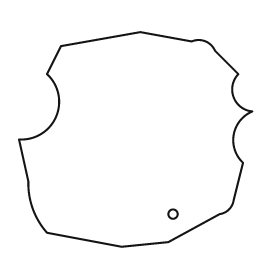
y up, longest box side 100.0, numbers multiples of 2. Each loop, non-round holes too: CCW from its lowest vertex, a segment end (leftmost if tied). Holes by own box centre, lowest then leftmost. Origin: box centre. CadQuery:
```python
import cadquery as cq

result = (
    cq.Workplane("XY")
    .moveTo(-6.0, -46.0)
    .lineTo(14.0, -44.0)
    .lineTo(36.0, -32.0)
    .threePointArc((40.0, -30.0), (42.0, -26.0))
    .lineTo(46.0, -10.0)
    .threePointArc((42.0, 2.0), (50.0, 12.0))
    .threePointArc((42.0, 18.0), (44.0, 28.0))
    .lineTo(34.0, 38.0)
    .threePointArc((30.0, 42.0), (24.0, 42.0))
    .lineTo(2.0, 46.0)
    .lineTo(-32.0, 40.0)
    .lineTo(-38.0, 28.0)
    .threePointArc((-34.0, 10.0), (-50.0, 0.0))
    .lineTo(-46.0, -18.0)
    .threePointArc((-44.0, -30.0), (-38.0, -40.0))
    .close()
    .moveTo(16.0, -32.0)
    .circle(2.0)
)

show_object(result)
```